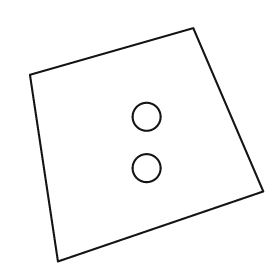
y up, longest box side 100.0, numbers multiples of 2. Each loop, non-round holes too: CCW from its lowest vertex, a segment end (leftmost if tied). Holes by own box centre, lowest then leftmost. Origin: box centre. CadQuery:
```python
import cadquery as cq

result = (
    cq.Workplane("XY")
    .moveTo(-38.0, -50.0)
    .lineTo(50.0, -20.0)
    .lineTo(20.0, 50.0)
    .lineTo(-50.0, 30.0)
    .close()
    .moveTo(0.0, -10.0)
    .circle(6.0)
    .moveTo(0.0, 12.0)
    .circle(6.0)
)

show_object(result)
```